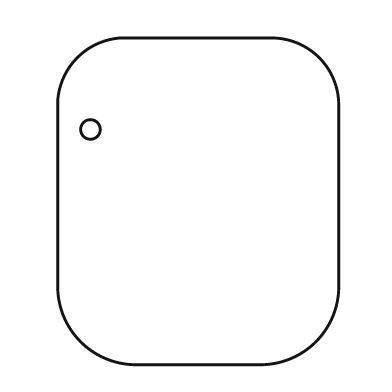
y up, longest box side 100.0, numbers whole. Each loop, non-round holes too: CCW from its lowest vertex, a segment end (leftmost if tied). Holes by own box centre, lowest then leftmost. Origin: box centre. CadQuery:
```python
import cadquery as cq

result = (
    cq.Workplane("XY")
    .moveTo(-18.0, -50.0)
    .lineTo(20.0, -50.0)
    .threePointArc((36.0, -43.0), (43.0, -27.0))
    .lineTo(43.0, 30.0)
    .threePointArc((37.0, 44.0), (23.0, 50.0))
    .lineTo(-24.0, 50.0)
    .threePointArc((-37.0, 44.0), (-43.0, 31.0))
    .lineTo(-43.0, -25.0)
    .threePointArc((-36.0, -43.0), (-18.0, -50.0))
    .close()
    .moveTo(-33.0, 22.0)
    .circle(3.0)
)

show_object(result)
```